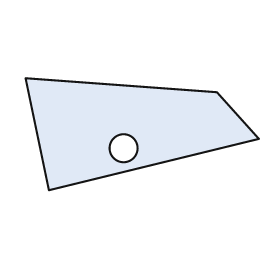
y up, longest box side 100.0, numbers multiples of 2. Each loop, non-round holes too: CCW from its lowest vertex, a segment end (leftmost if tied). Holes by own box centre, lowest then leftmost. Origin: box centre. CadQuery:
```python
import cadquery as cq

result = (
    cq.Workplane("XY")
    .moveTo(-40.0, -24.0)
    .lineTo(50.0, -2.0)
    .lineTo(32.0, 18.0)
    .lineTo(-50.0, 24.0)
    .close()
    .moveTo(-8.0, -6.0)
    .circle(6.0)
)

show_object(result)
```